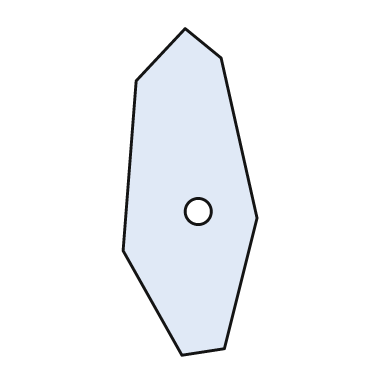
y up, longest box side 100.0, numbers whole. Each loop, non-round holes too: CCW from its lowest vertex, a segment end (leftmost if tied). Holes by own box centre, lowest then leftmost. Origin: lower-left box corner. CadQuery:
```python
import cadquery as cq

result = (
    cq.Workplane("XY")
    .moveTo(18.0, 0.0)
    .lineTo(31.0, 2.0)
    .lineTo(41.0, 42.0)
    .lineTo(30.0, 91.0)
    .lineTo(19.0, 100.0)
    .lineTo(4.0, 84.0)
    .lineTo(0.0, 32.0)
    .close()
    .moveTo(23.0, 44.0)
    .circle(4.0)
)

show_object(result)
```